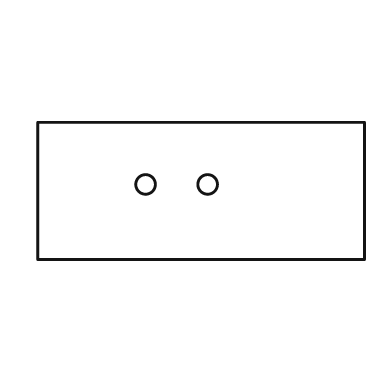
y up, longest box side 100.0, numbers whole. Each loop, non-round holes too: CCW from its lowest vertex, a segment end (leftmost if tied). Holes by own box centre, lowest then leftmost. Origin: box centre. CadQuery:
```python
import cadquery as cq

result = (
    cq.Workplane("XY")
    .moveTo(-50.0, -21.0)
    .lineTo(50.0, -21.0)
    .lineTo(50.0, 21.0)
    .lineTo(-50.0, 21.0)
    .close()
    .moveTo(-17.0, 2.0)
    .circle(3.0)
    .moveTo(2.0, 2.0)
    .circle(3.0)
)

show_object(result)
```